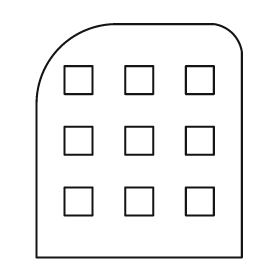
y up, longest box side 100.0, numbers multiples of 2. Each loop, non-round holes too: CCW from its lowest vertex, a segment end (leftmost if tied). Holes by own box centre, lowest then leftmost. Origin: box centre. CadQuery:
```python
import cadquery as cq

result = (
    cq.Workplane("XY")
    .moveTo(-44.0, -50.0)
    .lineTo(44.0, -50.0)
    .lineTo(44.0, 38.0)
    .threePointArc((40.0, 46.0), (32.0, 50.0))
    .lineTo(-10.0, 50.0)
    .threePointArc((-34.0, 40.0), (-44.0, 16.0))
    .close()
    .moveTo(-32.0, -32.0)
    .lineTo(-20.0, -32.0)
    .lineTo(-20.0, -20.0)
    .lineTo(-32.0, -20.0)
    .close()
    .moveTo(-6.0, -32.0)
    .lineTo(6.0, -32.0)
    .lineTo(6.0, -20.0)
    .lineTo(-6.0, -20.0)
    .close()
    .moveTo(20.0, -32.0)
    .lineTo(32.0, -32.0)
    .lineTo(32.0, -20.0)
    .lineTo(20.0, -20.0)
    .close()
    .moveTo(-32.0, -6.0)
    .lineTo(-20.0, -6.0)
    .lineTo(-20.0, 6.0)
    .lineTo(-32.0, 6.0)
    .close()
    .moveTo(-6.0, -6.0)
    .lineTo(6.0, -6.0)
    .lineTo(6.0, 6.0)
    .lineTo(-6.0, 6.0)
    .close()
    .moveTo(20.0, -6.0)
    .lineTo(32.0, -6.0)
    .lineTo(32.0, 6.0)
    .lineTo(20.0, 6.0)
    .close()
    .moveTo(-32.0, 20.0)
    .lineTo(-20.0, 20.0)
    .lineTo(-20.0, 32.0)
    .lineTo(-32.0, 32.0)
    .close()
    .moveTo(-6.0, 20.0)
    .lineTo(6.0, 20.0)
    .lineTo(6.0, 32.0)
    .lineTo(-6.0, 32.0)
    .close()
    .moveTo(20.0, 20.0)
    .lineTo(32.0, 20.0)
    .lineTo(32.0, 32.0)
    .lineTo(20.0, 32.0)
    .close()
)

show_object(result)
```